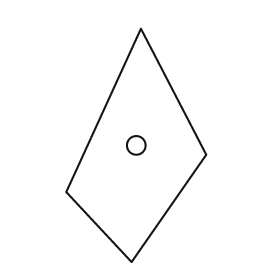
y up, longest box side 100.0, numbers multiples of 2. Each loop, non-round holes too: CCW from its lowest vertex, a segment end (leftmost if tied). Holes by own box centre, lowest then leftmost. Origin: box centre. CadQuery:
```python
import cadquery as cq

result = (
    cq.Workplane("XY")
    .moveTo(-2.0, -50.0)
    .lineTo(30.0, -4.0)
    .lineTo(2.0, 50.0)
    .lineTo(-30.0, -20.0)
    .close()
    .moveTo(0.0, 0.0)
    .circle(4.0)
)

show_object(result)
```